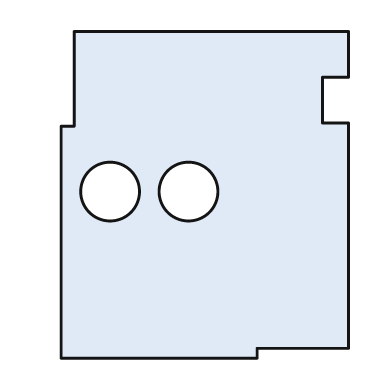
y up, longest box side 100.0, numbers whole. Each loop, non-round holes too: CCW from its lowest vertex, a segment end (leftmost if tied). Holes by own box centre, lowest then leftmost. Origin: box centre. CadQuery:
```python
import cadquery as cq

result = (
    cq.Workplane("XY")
    .moveTo(-44.0, -50.0)
    .lineTo(16.0, -50.0)
    .lineTo(16.0, -47.0)
    .lineTo(44.0, -47.0)
    .lineTo(44.0, 22.0)
    .lineTo(36.0, 22.0)
    .lineTo(36.0, 36.0)
    .lineTo(44.0, 36.0)
    .lineTo(44.0, 50.0)
    .lineTo(-40.0, 50.0)
    .lineTo(-40.0, 21.0)
    .lineTo(-44.0, 21.0)
    .close()
    .moveTo(-29.0, 1.0)
    .circle(9.0)
    .moveTo(-5.0, 1.0)
    .circle(9.0)
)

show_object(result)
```